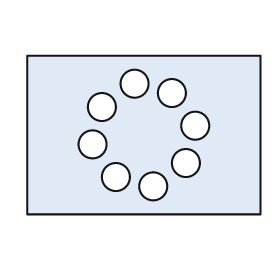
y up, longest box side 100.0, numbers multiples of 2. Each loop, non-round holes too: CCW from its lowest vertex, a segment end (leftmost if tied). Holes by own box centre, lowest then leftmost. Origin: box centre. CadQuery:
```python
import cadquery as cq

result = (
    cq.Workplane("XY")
    .moveTo(-50.0, -34.0)
    .lineTo(50.0, -34.0)
    .lineTo(50.0, 34.0)
    .lineTo(-50.0, 34.0)
    .close()
    .moveTo(4.0, -22.0)
    .circle(6.0)
    .moveTo(-12.0, -18.0)
    .circle(6.0)
    .moveTo(18.0, -12.0)
    .circle(6.0)
    .moveTo(-22.0, -4.0)
    .circle(6.0)
    .moveTo(22.0, 4.0)
    .circle(6.0)
    .moveTo(-18.0, 12.0)
    .circle(6.0)
    .moveTo(12.0, 18.0)
    .circle(6.0)
    .moveTo(-4.0, 22.0)
    .circle(6.0)
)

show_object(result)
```